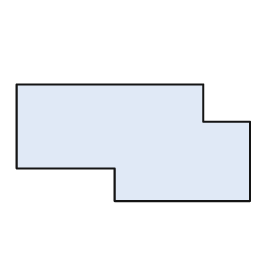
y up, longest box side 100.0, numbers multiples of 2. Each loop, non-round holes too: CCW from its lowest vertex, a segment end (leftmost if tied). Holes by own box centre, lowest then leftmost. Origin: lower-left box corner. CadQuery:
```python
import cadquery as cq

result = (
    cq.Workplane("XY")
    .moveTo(42.0, 0.0)
    .lineTo(100.0, 0.0)
    .lineTo(100.0, 34.0)
    .lineTo(80.0, 34.0)
    .lineTo(80.0, 50.0)
    .lineTo(0.0, 50.0)
    .lineTo(0.0, 14.0)
    .lineTo(42.0, 14.0)
    .close()
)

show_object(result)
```